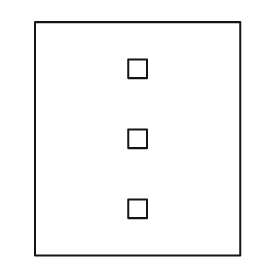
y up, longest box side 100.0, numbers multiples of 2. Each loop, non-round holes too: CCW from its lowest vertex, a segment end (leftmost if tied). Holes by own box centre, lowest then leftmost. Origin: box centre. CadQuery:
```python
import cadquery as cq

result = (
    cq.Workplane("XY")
    .moveTo(-44.0, -50.0)
    .lineTo(44.0, -50.0)
    .lineTo(44.0, 50.0)
    .lineTo(-44.0, 50.0)
    .close()
    .moveTo(-4.0, -34.0)
    .lineTo(4.0, -34.0)
    .lineTo(4.0, -26.0)
    .lineTo(-4.0, -26.0)
    .close()
    .moveTo(-4.0, -4.0)
    .lineTo(4.0, -4.0)
    .lineTo(4.0, 4.0)
    .lineTo(-4.0, 4.0)
    .close()
    .moveTo(-4.0, 26.0)
    .lineTo(4.0, 26.0)
    .lineTo(4.0, 34.0)
    .lineTo(-4.0, 34.0)
    .close()
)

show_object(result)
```